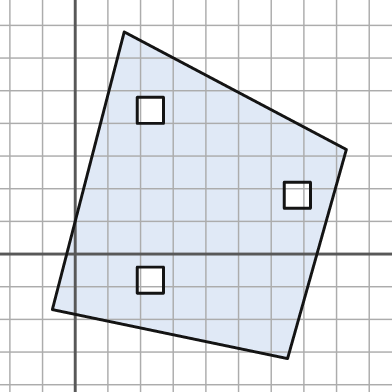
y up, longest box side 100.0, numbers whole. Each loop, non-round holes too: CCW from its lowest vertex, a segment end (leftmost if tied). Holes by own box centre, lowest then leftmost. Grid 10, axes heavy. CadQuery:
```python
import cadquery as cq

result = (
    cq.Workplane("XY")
    .moveTo(65.0, -32.0)
    .lineTo(83.0, 32.0)
    .lineTo(15.0, 68.0)
    .lineTo(-7.0, -17.0)
    .close()
    .moveTo(19.0, -12.0)
    .lineTo(27.0, -12.0)
    .lineTo(27.0, -4.0)
    .lineTo(19.0, -4.0)
    .close()
    .moveTo(64.0, 14.0)
    .lineTo(72.0, 14.0)
    .lineTo(72.0, 22.0)
    .lineTo(64.0, 22.0)
    .close()
    .moveTo(19.0, 40.0)
    .lineTo(27.0, 40.0)
    .lineTo(27.0, 48.0)
    .lineTo(19.0, 48.0)
    .close()
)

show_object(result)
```